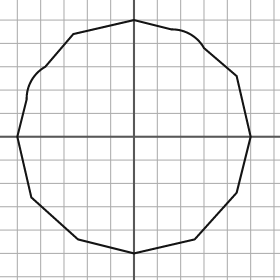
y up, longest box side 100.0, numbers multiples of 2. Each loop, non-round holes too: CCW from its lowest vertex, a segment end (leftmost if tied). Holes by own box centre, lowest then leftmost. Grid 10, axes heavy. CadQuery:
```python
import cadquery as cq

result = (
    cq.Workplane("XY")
    .moveTo(0.0, -50.0)
    .lineTo(26.0, -44.0)
    .lineTo(44.0, -24.0)
    .lineTo(50.0, 0.0)
    .lineTo(44.0, 26.0)
    .lineTo(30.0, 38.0)
    .threePointArc((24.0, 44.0), (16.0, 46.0))
    .lineTo(0.0, 50.0)
    .lineTo(-26.0, 44.0)
    .lineTo(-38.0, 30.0)
    .threePointArc((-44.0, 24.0), (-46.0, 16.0))
    .lineTo(-50.0, 0.0)
    .lineTo(-44.0, -26.0)
    .lineTo(-24.0, -44.0)
    .close()
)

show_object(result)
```